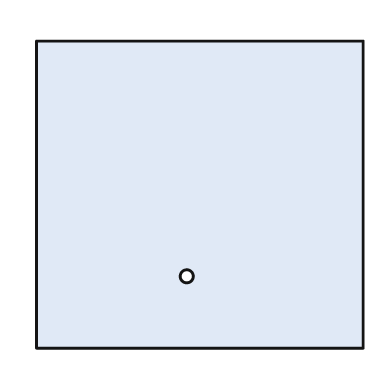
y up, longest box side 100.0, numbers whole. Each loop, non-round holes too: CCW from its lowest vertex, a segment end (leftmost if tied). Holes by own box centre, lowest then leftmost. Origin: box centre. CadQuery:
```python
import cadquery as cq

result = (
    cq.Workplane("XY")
    .moveTo(-50.0, -47.0)
    .lineTo(50.0, -47.0)
    .lineTo(50.0, 47.0)
    .lineTo(-50.0, 47.0)
    .close()
    .moveTo(-4.0, -25.0)
    .circle(2.0)
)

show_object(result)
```